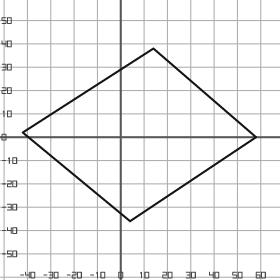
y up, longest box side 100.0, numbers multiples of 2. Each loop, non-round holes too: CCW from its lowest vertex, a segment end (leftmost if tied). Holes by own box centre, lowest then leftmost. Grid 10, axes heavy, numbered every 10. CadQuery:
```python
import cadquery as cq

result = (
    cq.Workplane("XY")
    .moveTo(4.0, -36.0)
    .lineTo(58.0, 0.0)
    .lineTo(14.0, 38.0)
    .lineTo(-42.0, 2.0)
    .close()
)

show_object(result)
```